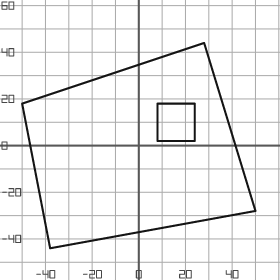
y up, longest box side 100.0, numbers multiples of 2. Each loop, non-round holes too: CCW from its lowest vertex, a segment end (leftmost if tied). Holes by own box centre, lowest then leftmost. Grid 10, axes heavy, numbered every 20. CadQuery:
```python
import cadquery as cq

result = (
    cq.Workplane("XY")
    .moveTo(-38.0, -44.0)
    .lineTo(50.0, -28.0)
    .lineTo(28.0, 44.0)
    .lineTo(-50.0, 18.0)
    .close()
    .moveTo(8.0, 2.0)
    .lineTo(24.0, 2.0)
    .lineTo(24.0, 18.0)
    .lineTo(8.0, 18.0)
    .close()
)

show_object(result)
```